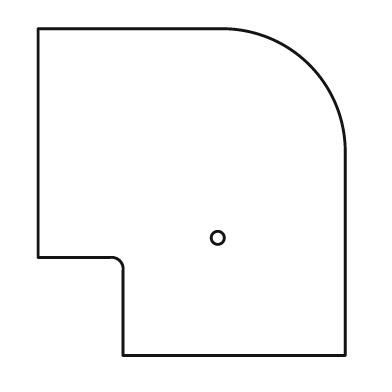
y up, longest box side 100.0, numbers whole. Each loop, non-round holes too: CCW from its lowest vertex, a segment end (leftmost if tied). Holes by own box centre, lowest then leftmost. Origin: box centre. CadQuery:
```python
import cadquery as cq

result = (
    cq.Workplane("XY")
    .moveTo(-21.0, -50.0)
    .lineTo(47.0, -50.0)
    .lineTo(47.0, 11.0)
    .threePointArc((36.0, 39.0), (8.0, 50.0))
    .lineTo(-47.0, 50.0)
    .lineTo(-47.0, -20.0)
    .lineTo(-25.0, -20.0)
    .threePointArc((-22.0, -21.0), (-21.0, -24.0))
    .close()
    .moveTo(8.0, -14.0)
    .circle(2.0)
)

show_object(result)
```